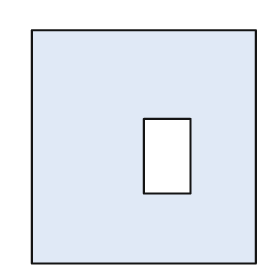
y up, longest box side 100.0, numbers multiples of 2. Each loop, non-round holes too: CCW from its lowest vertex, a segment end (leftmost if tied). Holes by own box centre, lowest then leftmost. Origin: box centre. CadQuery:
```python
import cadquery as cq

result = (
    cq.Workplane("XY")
    .moveTo(-48.0, -50.0)
    .lineTo(48.0, -50.0)
    .lineTo(48.0, 50.0)
    .lineTo(-48.0, 50.0)
    .close()
    .moveTo(0.0, -20.0)
    .lineTo(20.0, -20.0)
    .lineTo(20.0, 12.0)
    .lineTo(0.0, 12.0)
    .close()
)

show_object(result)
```